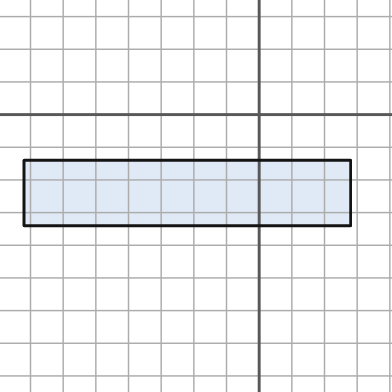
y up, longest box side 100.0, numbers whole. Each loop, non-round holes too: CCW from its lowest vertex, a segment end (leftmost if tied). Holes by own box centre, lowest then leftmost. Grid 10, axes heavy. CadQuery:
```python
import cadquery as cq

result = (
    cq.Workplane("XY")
    .moveTo(-72.0, -34.0)
    .lineTo(28.0, -34.0)
    .lineTo(28.0, -14.0)
    .lineTo(-72.0, -14.0)
    .close()
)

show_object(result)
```